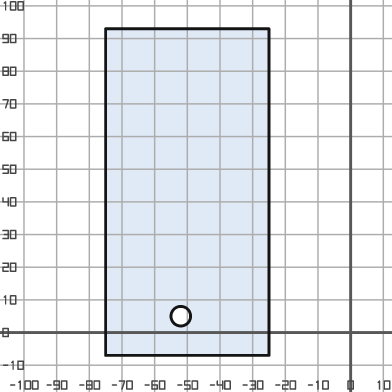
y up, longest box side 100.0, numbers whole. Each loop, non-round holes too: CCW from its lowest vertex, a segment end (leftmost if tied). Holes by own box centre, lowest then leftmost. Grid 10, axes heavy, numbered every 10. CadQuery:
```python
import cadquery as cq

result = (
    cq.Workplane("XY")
    .moveTo(-75.0, -7.0)
    .lineTo(-25.0, -7.0)
    .lineTo(-25.0, 93.0)
    .lineTo(-75.0, 93.0)
    .close()
    .moveTo(-52.0, 5.0)
    .circle(3.0)
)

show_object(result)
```